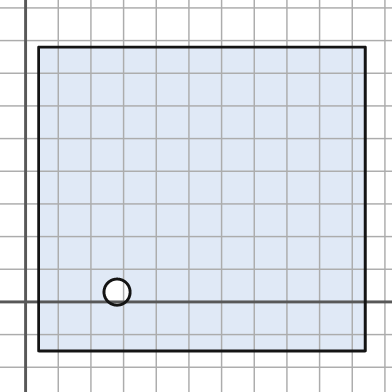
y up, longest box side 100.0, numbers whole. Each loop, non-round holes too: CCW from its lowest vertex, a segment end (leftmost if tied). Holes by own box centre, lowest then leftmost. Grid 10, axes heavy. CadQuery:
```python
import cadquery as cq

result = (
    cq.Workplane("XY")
    .moveTo(4.0, -15.0)
    .lineTo(104.0, -15.0)
    .lineTo(104.0, 78.0)
    .lineTo(4.0, 78.0)
    .close()
    .moveTo(28.0, 3.0)
    .circle(4.0)
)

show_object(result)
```